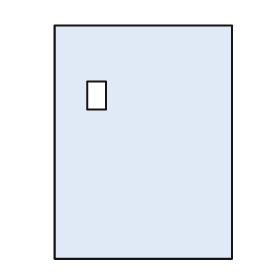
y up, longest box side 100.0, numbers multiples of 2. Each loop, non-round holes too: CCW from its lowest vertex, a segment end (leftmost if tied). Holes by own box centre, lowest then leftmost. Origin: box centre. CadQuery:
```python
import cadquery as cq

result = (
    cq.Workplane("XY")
    .moveTo(-38.0, -50.0)
    .lineTo(38.0, -50.0)
    .lineTo(38.0, 50.0)
    .lineTo(-38.0, 50.0)
    .close()
    .moveTo(-24.0, 14.0)
    .lineTo(-16.0, 14.0)
    .lineTo(-16.0, 26.0)
    .lineTo(-24.0, 26.0)
    .close()
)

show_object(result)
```